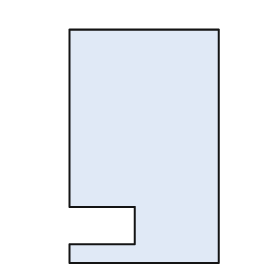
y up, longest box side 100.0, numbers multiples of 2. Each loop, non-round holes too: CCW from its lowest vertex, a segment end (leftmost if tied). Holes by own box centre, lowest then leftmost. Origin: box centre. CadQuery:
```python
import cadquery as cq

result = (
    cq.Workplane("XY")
    .moveTo(-32.0, -50.0)
    .lineTo(32.0, -50.0)
    .lineTo(32.0, 50.0)
    .lineTo(-32.0, 50.0)
    .lineTo(-32.0, -26.0)
    .lineTo(-4.0, -26.0)
    .lineTo(-4.0, -42.0)
    .lineTo(-32.0, -42.0)
    .close()
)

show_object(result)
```